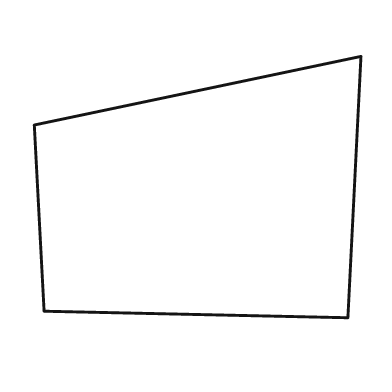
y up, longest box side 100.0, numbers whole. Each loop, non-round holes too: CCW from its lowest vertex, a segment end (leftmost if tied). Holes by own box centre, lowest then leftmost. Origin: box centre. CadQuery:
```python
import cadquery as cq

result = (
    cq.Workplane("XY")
    .moveTo(46.0, -40.0)
    .lineTo(50.0, 40.0)
    .lineTo(-50.0, 19.0)
    .lineTo(-47.0, -38.0)
    .close()
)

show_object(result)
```